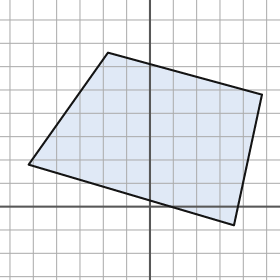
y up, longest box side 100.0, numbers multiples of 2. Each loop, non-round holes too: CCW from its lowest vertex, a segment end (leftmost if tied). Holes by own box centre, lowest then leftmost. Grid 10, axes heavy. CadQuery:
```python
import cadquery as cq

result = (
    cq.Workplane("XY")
    .moveTo(36.0, -8.0)
    .lineTo(48.0, 48.0)
    .lineTo(-18.0, 66.0)
    .lineTo(-52.0, 18.0)
    .close()
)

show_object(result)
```